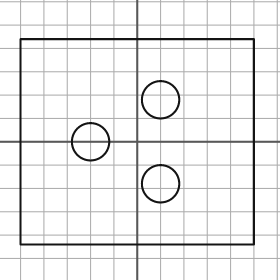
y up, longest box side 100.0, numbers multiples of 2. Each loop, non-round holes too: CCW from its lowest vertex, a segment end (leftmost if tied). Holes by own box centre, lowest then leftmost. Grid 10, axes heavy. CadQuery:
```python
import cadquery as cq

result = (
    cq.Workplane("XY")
    .moveTo(-50.0, -44.0)
    .lineTo(50.0, -44.0)
    .lineTo(50.0, 44.0)
    .lineTo(-50.0, 44.0)
    .close()
    .moveTo(10.0, -18.0)
    .circle(8.0)
    .moveTo(-20.0, 0.0)
    .circle(8.0)
    .moveTo(10.0, 18.0)
    .circle(8.0)
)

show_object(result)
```